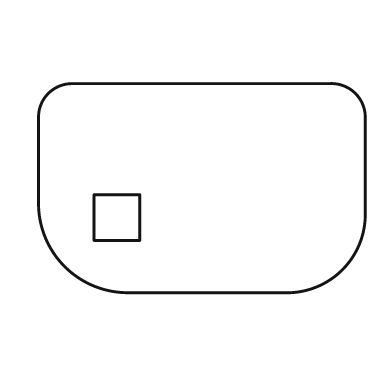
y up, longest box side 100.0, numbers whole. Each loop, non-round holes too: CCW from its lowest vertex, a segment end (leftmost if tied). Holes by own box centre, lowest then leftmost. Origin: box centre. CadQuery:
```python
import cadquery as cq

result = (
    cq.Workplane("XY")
    .moveTo(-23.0, -32.0)
    .lineTo(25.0, -32.0)
    .threePointArc((43.0, -25.0), (50.0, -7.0))
    .lineTo(50.0, 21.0)
    .threePointArc((47.0, 29.0), (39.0, 32.0))
    .lineTo(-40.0, 32.0)
    .threePointArc((-47.0, 29.0), (-50.0, 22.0))
    .lineTo(-50.0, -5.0)
    .threePointArc((-42.0, -24.0), (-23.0, -32.0))
    .close()
    .moveTo(-33.0, -16.0)
    .lineTo(-19.0, -16.0)
    .lineTo(-19.0, -2.0)
    .lineTo(-33.0, -2.0)
    .close()
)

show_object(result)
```